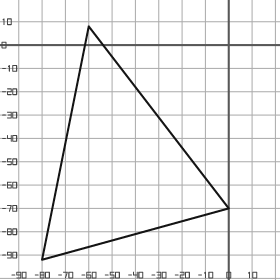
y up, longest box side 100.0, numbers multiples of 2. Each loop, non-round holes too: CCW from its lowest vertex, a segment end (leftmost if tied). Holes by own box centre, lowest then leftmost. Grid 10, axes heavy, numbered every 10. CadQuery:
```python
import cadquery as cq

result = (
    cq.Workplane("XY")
    .moveTo(-80.0, -92.0)
    .lineTo(0.0, -70.0)
    .lineTo(-60.0, 8.0)
    .close()
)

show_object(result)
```